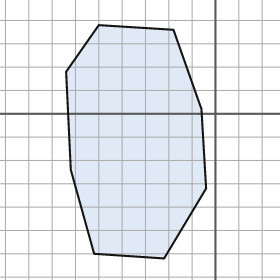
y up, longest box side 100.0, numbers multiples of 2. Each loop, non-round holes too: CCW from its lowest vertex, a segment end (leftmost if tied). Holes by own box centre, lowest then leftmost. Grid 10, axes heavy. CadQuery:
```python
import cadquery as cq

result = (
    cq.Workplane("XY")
    .moveTo(-22.0, -62.0)
    .lineTo(-4.0, -32.0)
    .lineTo(-6.0, 2.0)
    .lineTo(-18.0, 36.0)
    .lineTo(-50.0, 38.0)
    .lineTo(-64.0, 18.0)
    .lineTo(-62.0, -24.0)
    .lineTo(-52.0, -60.0)
    .close()
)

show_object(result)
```